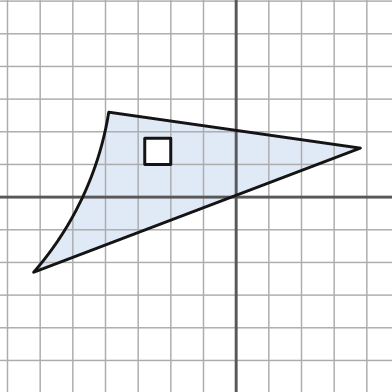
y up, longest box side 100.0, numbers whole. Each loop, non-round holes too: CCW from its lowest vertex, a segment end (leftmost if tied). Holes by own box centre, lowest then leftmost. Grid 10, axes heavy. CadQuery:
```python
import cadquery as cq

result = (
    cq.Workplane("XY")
    .moveTo(-62.0, -23.0)
    .lineTo(38.0, 15.0)
    .lineTo(-39.0, 26.0)
    .threePointArc((-47.0, 0.0), (-62.0, -23.0))
    .close()
    .moveTo(-28.0, 10.0)
    .lineTo(-20.0, 10.0)
    .lineTo(-20.0, 18.0)
    .lineTo(-28.0, 18.0)
    .close()
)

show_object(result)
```